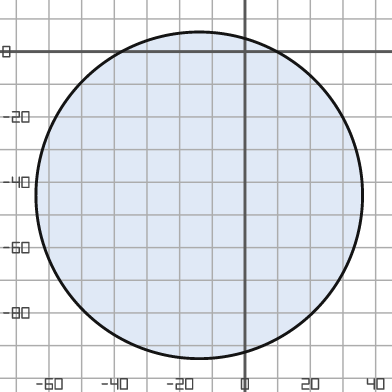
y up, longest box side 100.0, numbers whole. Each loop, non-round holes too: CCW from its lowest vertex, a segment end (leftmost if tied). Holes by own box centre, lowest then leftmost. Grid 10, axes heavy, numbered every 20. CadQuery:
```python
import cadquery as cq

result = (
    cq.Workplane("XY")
    .moveTo(-14.0, -44.0)
    .circle(50.0)
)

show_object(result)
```